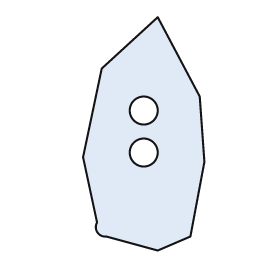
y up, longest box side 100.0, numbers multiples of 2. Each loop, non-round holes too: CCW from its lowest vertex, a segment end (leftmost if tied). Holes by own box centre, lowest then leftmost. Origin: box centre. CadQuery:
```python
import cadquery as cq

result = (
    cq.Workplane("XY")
    .moveTo(6.0, -50.0)
    .lineTo(20.0, -44.0)
    .lineTo(26.0, -12.0)
    .lineTo(24.0, 16.0)
    .lineTo(6.0, 50.0)
    .lineTo(-18.0, 28.0)
    .lineTo(-26.0, -10.0)
    .lineTo(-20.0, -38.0)
    .threePointArc((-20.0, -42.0), (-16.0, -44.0))
    .close()
    .moveTo(0.0, -8.0)
    .circle(6.0)
    .moveTo(0.0, 10.0)
    .circle(6.0)
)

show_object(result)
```